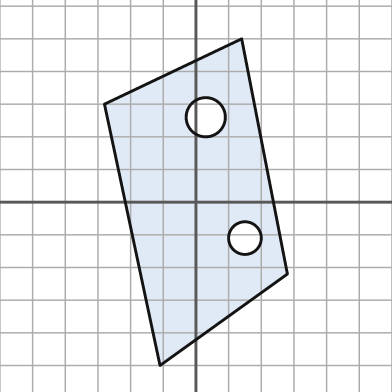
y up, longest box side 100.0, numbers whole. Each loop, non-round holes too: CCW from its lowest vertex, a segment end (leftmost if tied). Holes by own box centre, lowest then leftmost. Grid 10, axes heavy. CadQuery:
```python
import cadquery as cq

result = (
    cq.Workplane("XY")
    .moveTo(-11.0, -50.0)
    .lineTo(28.0, -22.0)
    .lineTo(14.0, 50.0)
    .lineTo(-28.0, 30.0)
    .close()
    .moveTo(15.0, -11.0)
    .circle(5.0)
    .moveTo(3.0, 26.0)
    .circle(6.0)
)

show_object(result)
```